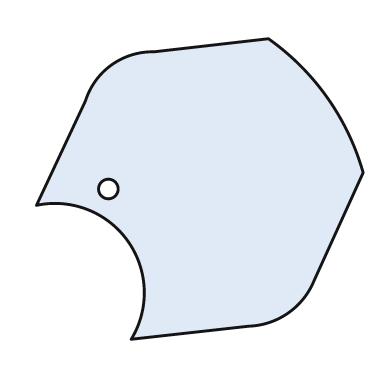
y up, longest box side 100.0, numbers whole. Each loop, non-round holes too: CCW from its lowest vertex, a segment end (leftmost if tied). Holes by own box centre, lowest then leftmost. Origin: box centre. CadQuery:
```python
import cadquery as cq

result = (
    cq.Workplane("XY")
    .moveTo(-21.0, -46.0)
    .lineTo(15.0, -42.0)
    .threePointArc((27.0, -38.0), (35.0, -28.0))
    .lineTo(50.0, 5.0)
    .threePointArc((39.0, 28.0), (21.0, 46.0))
    .lineTo(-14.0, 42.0)
    .threePointArc((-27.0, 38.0), (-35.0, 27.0))
    .lineTo(-50.0, -5.0)
    .threePointArc((-22.0, -16.0), (-21.0, -46.0))
    .close()
    .moveTo(-28.0, 0.0)
    .circle(3.0)
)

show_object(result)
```